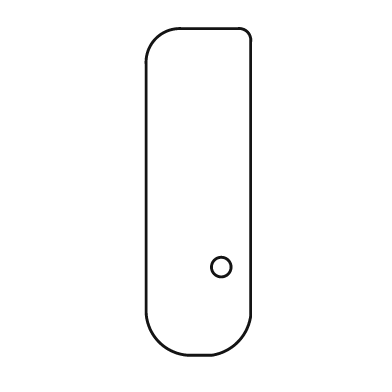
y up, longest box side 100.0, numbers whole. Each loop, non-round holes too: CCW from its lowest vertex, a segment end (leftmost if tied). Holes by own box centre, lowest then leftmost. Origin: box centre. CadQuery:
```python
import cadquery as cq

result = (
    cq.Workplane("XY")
    .moveTo(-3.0, -50.0)
    .lineTo(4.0, -50.0)
    .threePointArc((12.0, -46.0), (16.0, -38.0))
    .lineTo(16.0, 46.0)
    .threePointArc((15.0, 49.0), (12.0, 50.0))
    .lineTo(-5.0, 50.0)
    .threePointArc((-13.0, 47.0), (-16.0, 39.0))
    .lineTo(-16.0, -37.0)
    .threePointArc((-12.0, -46.0), (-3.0, -50.0))
    .close()
    .moveTo(7.0, -23.0)
    .circle(3.0)
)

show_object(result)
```